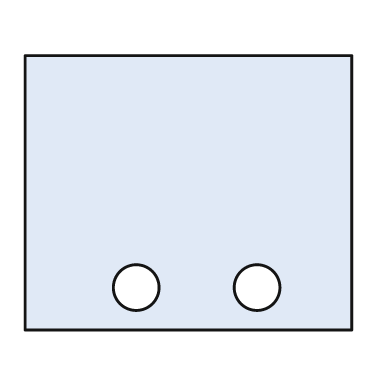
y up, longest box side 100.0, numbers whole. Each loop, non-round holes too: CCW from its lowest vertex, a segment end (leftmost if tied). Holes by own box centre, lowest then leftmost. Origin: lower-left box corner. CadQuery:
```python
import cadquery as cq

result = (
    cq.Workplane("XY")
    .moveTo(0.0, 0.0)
    .lineTo(100.0, 0.0)
    .lineTo(100.0, 84.0)
    .lineTo(0.0, 84.0)
    .close()
    .moveTo(34.0, 13.0)
    .circle(7.0)
    .moveTo(71.0, 13.0)
    .circle(7.0)
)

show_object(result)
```